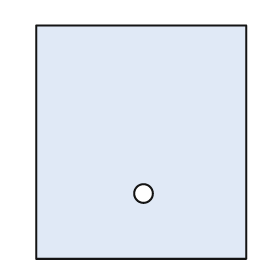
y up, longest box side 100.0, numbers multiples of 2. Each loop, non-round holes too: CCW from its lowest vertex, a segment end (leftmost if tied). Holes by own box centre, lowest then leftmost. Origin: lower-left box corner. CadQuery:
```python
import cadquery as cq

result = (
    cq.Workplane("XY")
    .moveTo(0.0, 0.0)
    .lineTo(90.0, 0.0)
    .lineTo(90.0, 100.0)
    .lineTo(0.0, 100.0)
    .close()
    .moveTo(46.0, 28.0)
    .circle(4.0)
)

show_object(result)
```